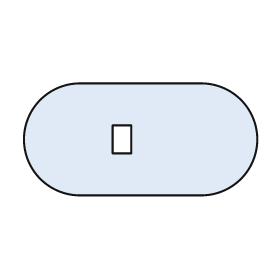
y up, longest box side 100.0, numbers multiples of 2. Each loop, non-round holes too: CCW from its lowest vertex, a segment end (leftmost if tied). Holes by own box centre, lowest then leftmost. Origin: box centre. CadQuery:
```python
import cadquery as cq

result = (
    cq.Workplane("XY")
    .moveTo(-26.0, -24.0)
    .lineTo(26.0, -24.0)
    .threePointArc((50.0, 0.0), (26.0, 24.0))
    .lineTo(-26.0, 24.0)
    .threePointArc((-50.0, 0.0), (-26.0, -24.0))
    .close()
    .moveTo(-12.0, -6.0)
    .lineTo(-4.0, -6.0)
    .lineTo(-4.0, 6.0)
    .lineTo(-12.0, 6.0)
    .close()
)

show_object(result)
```